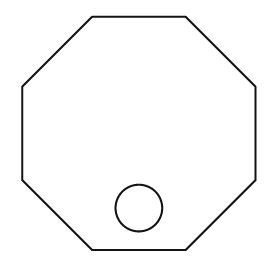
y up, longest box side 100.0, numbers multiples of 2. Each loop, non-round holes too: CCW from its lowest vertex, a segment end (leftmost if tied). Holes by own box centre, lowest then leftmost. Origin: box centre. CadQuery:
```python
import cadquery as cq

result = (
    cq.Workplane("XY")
    .moveTo(-20.0, -50.0)
    .lineTo(20.0, -50.0)
    .lineTo(50.0, -20.0)
    .lineTo(50.0, 20.0)
    .lineTo(20.0, 50.0)
    .lineTo(-20.0, 50.0)
    .lineTo(-50.0, 20.0)
    .lineTo(-50.0, -20.0)
    .close()
    .moveTo(0.0, -32.0)
    .circle(10.0)
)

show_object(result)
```